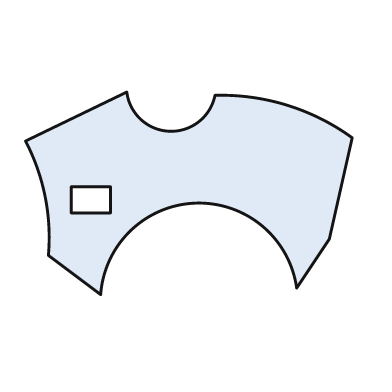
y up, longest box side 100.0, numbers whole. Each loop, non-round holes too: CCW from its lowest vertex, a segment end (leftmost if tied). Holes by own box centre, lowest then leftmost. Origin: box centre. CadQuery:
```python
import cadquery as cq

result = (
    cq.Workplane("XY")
    .moveTo(-27.0, -31.0)
    .threePointArc((2.0, -3.0), (33.0, -29.0))
    .lineTo(43.0, -14.0)
    .lineTo(50.0, 17.0)
    .threePointArc((30.0, 27.0), (8.0, 30.0))
    .threePointArc((-6.0, 19.0), (-19.0, 31.0))
    .lineTo(-50.0, 16.0)
    .threePointArc((-44.0, -1.0), (-43.0, -19.0))
    .close()
    .moveTo(-36.0, -6.0)
    .lineTo(-24.0, -6.0)
    .lineTo(-24.0, 2.0)
    .lineTo(-36.0, 2.0)
    .close()
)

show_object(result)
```